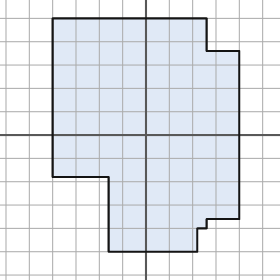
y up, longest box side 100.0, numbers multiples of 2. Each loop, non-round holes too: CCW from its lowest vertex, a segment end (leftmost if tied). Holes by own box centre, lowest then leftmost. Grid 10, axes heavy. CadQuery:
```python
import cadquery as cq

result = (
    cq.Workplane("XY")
    .moveTo(-16.0, -50.0)
    .lineTo(22.0, -50.0)
    .lineTo(22.0, -40.0)
    .lineTo(26.0, -40.0)
    .lineTo(26.0, -36.0)
    .lineTo(40.0, -36.0)
    .lineTo(40.0, 36.0)
    .lineTo(26.0, 36.0)
    .lineTo(26.0, 50.0)
    .lineTo(-40.0, 50.0)
    .lineTo(-40.0, -18.0)
    .lineTo(-16.0, -18.0)
    .close()
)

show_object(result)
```